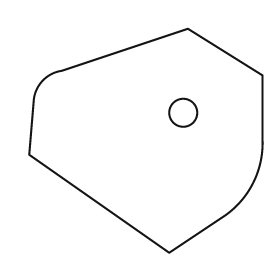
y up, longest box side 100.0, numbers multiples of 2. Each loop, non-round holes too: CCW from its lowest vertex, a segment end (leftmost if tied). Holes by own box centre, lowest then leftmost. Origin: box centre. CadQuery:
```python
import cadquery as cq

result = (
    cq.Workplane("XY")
    .moveTo(10.0, -48.0)
    .lineTo(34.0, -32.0)
    .threePointArc((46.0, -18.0), (50.0, 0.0))
    .lineTo(50.0, 28.0)
    .lineTo(18.0, 48.0)
    .lineTo(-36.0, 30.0)
    .threePointArc((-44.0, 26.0), (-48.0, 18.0))
    .lineTo(-50.0, -6.0)
    .close()
    .moveTo(16.0, 12.0)
    .circle(6.0)
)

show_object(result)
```